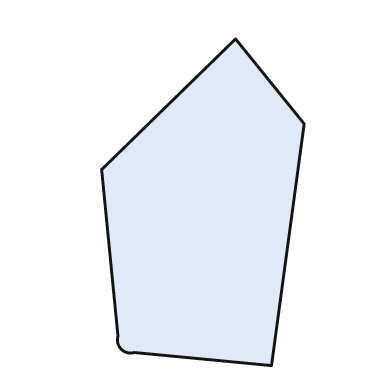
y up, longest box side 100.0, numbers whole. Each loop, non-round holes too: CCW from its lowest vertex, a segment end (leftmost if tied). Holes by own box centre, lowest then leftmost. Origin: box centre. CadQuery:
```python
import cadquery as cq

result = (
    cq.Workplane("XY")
    .moveTo(21.0, -50.0)
    .lineTo(31.0, 24.0)
    .lineTo(10.0, 50.0)
    .lineTo(-31.0, 10.0)
    .lineTo(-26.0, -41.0)
    .threePointArc((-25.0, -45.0), (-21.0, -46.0))
    .close()
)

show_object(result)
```